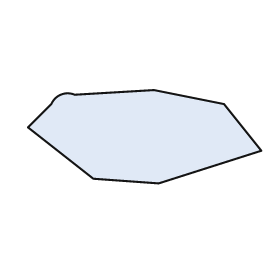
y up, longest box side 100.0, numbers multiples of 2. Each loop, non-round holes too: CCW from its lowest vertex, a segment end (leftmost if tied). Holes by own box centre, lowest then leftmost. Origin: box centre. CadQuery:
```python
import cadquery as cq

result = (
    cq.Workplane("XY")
    .moveTo(6.0, -20.0)
    .lineTo(50.0, -6.0)
    .lineTo(34.0, 14.0)
    .lineTo(4.0, 20.0)
    .lineTo(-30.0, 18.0)
    .threePointArc((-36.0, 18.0), (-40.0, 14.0))
    .lineTo(-50.0, 4.0)
    .lineTo(-22.0, -18.0)
    .close()
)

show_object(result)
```